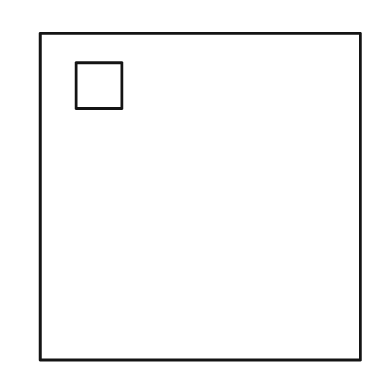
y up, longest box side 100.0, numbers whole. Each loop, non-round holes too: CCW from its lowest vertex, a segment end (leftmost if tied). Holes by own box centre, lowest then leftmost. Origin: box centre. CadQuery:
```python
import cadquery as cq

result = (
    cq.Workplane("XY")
    .moveTo(-49.0, -50.0)
    .lineTo(49.0, -50.0)
    .lineTo(49.0, 50.0)
    .lineTo(-49.0, 50.0)
    .close()
    .moveTo(-38.0, 27.0)
    .lineTo(-24.0, 27.0)
    .lineTo(-24.0, 41.0)
    .lineTo(-38.0, 41.0)
    .close()
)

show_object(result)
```